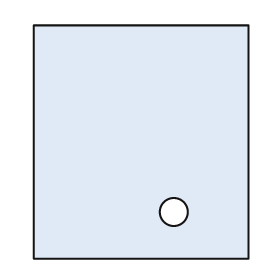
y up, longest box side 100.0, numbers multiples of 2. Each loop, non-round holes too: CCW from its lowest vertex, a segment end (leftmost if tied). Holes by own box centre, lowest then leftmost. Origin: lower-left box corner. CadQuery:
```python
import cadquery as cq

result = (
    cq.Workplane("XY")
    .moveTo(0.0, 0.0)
    .lineTo(92.0, 0.0)
    .lineTo(92.0, 100.0)
    .lineTo(0.0, 100.0)
    .close()
    .moveTo(60.0, 20.0)
    .circle(6.0)
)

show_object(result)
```